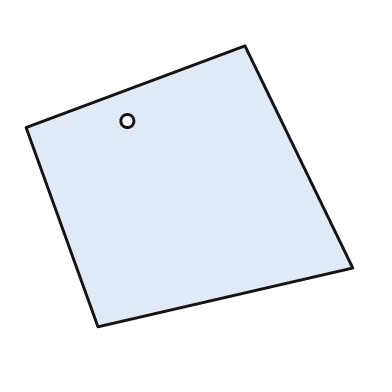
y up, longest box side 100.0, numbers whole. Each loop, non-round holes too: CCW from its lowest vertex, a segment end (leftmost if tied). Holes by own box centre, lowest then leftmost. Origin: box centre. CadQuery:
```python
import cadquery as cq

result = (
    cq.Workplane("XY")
    .moveTo(-28.0, -43.0)
    .lineTo(50.0, -25.0)
    .lineTo(17.0, 43.0)
    .lineTo(-50.0, 18.0)
    .close()
    .moveTo(-19.0, 20.0)
    .circle(2.0)
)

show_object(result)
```